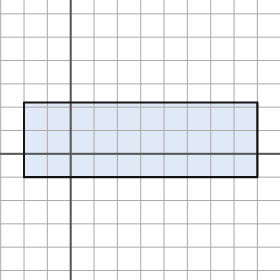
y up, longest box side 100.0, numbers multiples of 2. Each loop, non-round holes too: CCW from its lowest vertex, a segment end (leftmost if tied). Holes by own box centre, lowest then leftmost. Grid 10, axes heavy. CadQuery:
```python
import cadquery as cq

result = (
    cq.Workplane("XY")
    .moveTo(-20.0, -10.0)
    .lineTo(80.0, -10.0)
    .lineTo(80.0, 22.0)
    .lineTo(-20.0, 22.0)
    .close()
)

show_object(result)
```